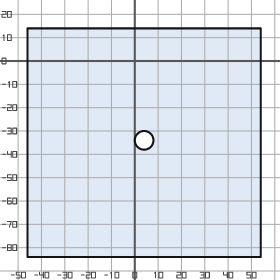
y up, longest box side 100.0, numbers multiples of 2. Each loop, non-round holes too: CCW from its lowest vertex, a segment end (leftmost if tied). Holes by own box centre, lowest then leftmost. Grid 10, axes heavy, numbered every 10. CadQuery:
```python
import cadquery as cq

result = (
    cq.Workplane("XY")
    .moveTo(-46.0, -84.0)
    .lineTo(54.0, -84.0)
    .lineTo(54.0, 14.0)
    .lineTo(-46.0, 14.0)
    .close()
    .moveTo(4.0, -34.0)
    .circle(4.0)
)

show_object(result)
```